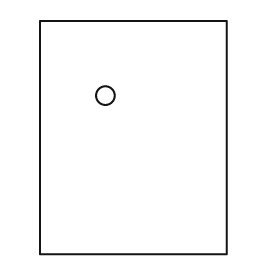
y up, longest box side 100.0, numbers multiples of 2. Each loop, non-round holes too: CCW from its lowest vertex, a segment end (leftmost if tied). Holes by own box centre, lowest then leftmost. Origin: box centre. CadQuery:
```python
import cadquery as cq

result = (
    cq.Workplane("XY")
    .moveTo(-40.0, -50.0)
    .lineTo(40.0, -50.0)
    .lineTo(40.0, 50.0)
    .lineTo(-40.0, 50.0)
    .close()
    .moveTo(-12.0, 18.0)
    .circle(4.0)
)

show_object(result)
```